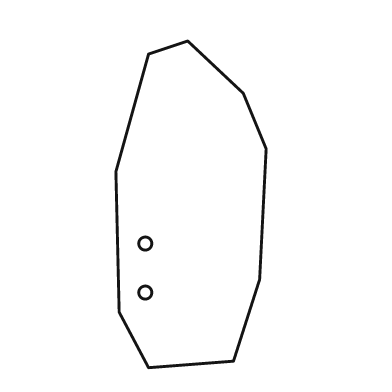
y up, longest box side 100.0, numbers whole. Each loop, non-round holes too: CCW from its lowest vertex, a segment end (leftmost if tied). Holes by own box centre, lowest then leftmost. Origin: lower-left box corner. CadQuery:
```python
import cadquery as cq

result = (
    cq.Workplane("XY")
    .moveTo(10.0, 0.0)
    .lineTo(36.0, 2.0)
    .lineTo(44.0, 27.0)
    .lineTo(46.0, 67.0)
    .lineTo(39.0, 84.0)
    .lineTo(22.0, 100.0)
    .lineTo(10.0, 96.0)
    .lineTo(0.0, 60.0)
    .lineTo(1.0, 17.0)
    .close()
    .moveTo(9.0, 23.0)
    .circle(2.0)
    .moveTo(9.0, 38.0)
    .circle(2.0)
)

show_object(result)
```